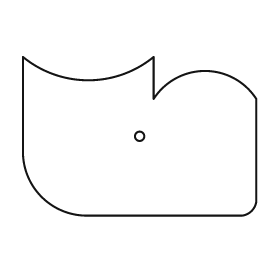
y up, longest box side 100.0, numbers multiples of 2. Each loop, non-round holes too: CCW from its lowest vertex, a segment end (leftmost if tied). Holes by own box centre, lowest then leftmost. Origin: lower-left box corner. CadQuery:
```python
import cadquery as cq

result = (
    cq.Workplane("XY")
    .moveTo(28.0, 0.0)
    .lineTo(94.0, 0.0)
    .threePointArc((98.0, 2.0), (100.0, 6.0))
    .lineTo(100.0, 50.0)
    .threePointArc((78.0, 62.0), (56.0, 50.0))
    .lineTo(56.0, 68.0)
    .threePointArc((28.0, 58.0), (0.0, 68.0))
    .lineTo(0.0, 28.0)
    .threePointArc((8.0, 8.0), (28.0, 0.0))
    .close()
    .moveTo(50.0, 34.0)
    .circle(2.0)
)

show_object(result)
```